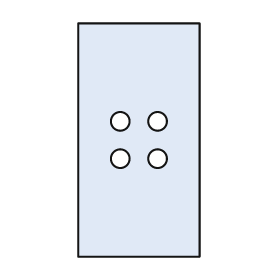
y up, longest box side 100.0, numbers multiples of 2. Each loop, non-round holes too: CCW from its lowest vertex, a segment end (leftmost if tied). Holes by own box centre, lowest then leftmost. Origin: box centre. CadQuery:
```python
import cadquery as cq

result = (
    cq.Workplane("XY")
    .moveTo(-26.0, -50.0)
    .lineTo(26.0, -50.0)
    .lineTo(26.0, 50.0)
    .lineTo(-26.0, 50.0)
    .close()
    .moveTo(-8.0, -8.0)
    .circle(4.0)
    .moveTo(8.0, -8.0)
    .circle(4.0)
    .moveTo(-8.0, 8.0)
    .circle(4.0)
    .moveTo(8.0, 8.0)
    .circle(4.0)
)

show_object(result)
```